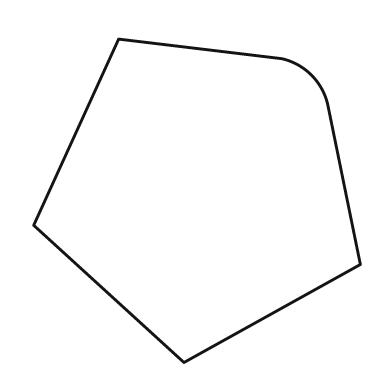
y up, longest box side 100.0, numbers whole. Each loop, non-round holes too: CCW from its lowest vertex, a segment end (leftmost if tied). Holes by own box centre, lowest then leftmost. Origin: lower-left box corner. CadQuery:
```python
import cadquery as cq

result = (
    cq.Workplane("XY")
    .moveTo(46.0, 0.0)
    .lineTo(100.0, 30.0)
    .lineTo(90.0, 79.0)
    .threePointArc((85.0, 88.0), (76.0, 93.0))
    .lineTo(26.0, 99.0)
    .lineTo(0.0, 42.0)
    .close()
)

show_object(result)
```